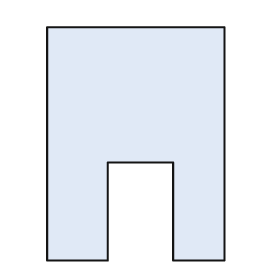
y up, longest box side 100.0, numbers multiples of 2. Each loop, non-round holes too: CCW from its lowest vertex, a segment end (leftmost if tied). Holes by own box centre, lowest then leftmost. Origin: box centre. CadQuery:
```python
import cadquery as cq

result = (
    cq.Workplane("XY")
    .moveTo(-38.0, -50.0)
    .lineTo(-12.0, -50.0)
    .lineTo(-12.0, -8.0)
    .lineTo(16.0, -8.0)
    .lineTo(16.0, -50.0)
    .lineTo(38.0, -50.0)
    .lineTo(38.0, 50.0)
    .lineTo(-38.0, 50.0)
    .close()
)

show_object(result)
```